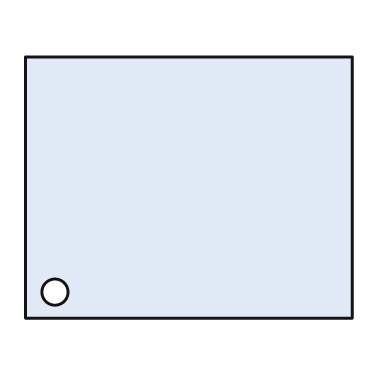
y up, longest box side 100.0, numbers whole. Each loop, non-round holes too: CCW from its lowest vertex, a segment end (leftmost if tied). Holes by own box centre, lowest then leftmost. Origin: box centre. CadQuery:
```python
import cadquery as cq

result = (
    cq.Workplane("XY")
    .moveTo(-50.0, -40.0)
    .lineTo(50.0, -40.0)
    .lineTo(50.0, 40.0)
    .lineTo(-50.0, 40.0)
    .close()
    .moveTo(-41.0, -32.0)
    .circle(4.0)
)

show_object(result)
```